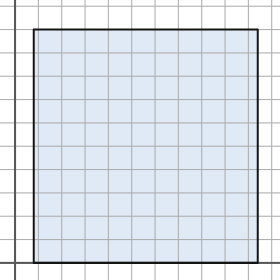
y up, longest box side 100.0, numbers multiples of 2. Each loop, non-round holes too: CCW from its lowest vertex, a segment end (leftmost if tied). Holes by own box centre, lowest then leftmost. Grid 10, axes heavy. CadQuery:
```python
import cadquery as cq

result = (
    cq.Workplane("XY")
    .moveTo(8.0, 0.0)
    .lineTo(104.0, 0.0)
    .lineTo(104.0, 100.0)
    .lineTo(8.0, 100.0)
    .close()
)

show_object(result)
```